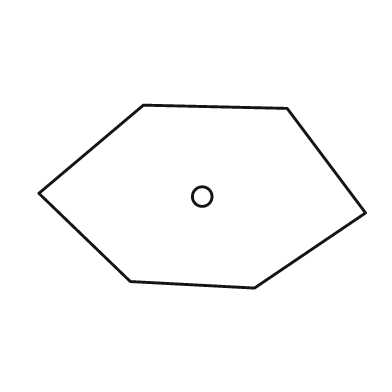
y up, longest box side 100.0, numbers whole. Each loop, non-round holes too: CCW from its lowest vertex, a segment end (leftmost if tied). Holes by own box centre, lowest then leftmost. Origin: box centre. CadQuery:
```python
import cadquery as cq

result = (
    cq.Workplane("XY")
    .moveTo(16.0, -28.0)
    .lineTo(50.0, -5.0)
    .lineTo(26.0, 27.0)
    .lineTo(-18.0, 28.0)
    .lineTo(-50.0, 1.0)
    .lineTo(-22.0, -26.0)
    .close()
    .moveTo(0.0, 0.0)
    .circle(3.0)
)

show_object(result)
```